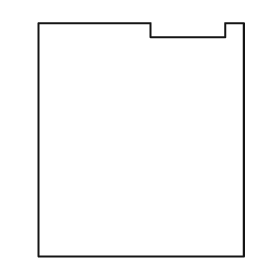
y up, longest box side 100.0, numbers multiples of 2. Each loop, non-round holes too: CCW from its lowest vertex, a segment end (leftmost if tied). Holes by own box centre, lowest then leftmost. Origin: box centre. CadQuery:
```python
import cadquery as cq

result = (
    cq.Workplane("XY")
    .moveTo(-44.0, -50.0)
    .lineTo(44.0, -50.0)
    .lineTo(44.0, 50.0)
    .lineTo(36.0, 50.0)
    .lineTo(36.0, 44.0)
    .lineTo(4.0, 44.0)
    .lineTo(4.0, 50.0)
    .lineTo(-44.0, 50.0)
    .close()
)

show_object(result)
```